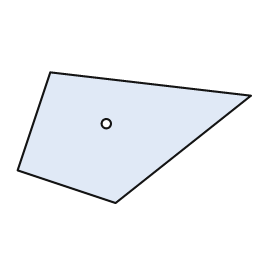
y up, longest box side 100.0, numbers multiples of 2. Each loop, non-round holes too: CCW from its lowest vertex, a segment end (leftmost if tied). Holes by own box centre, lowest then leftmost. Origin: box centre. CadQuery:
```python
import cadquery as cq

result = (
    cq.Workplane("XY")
    .moveTo(-8.0, -28.0)
    .lineTo(50.0, 18.0)
    .lineTo(-36.0, 28.0)
    .lineTo(-50.0, -14.0)
    .close()
    .moveTo(-12.0, 6.0)
    .circle(2.0)
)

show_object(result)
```